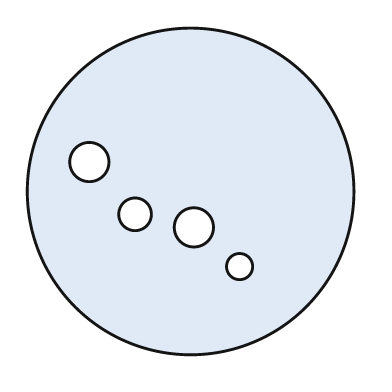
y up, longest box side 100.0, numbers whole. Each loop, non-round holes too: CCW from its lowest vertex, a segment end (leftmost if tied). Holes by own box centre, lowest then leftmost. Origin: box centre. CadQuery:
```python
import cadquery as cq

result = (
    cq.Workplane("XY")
    .moveTo(0.0, 0.0)
    .circle(50.0)
    .moveTo(15.0, -23.0)
    .circle(4.0)
    .moveTo(1.0, -11.0)
    .circle(6.0)
    .moveTo(-17.0, -7.0)
    .circle(5.0)
    .moveTo(-31.0, 9.0)
    .circle(6.0)
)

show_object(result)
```